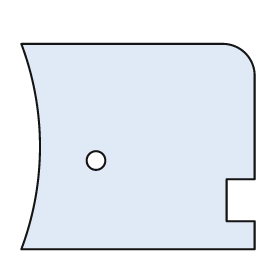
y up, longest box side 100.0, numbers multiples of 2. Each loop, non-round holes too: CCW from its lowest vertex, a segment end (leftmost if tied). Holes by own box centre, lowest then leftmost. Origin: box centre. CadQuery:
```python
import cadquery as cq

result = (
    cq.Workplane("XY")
    .moveTo(-50.0, -44.0)
    .lineTo(50.0, -44.0)
    .lineTo(50.0, -32.0)
    .lineTo(38.0, -32.0)
    .lineTo(38.0, -14.0)
    .lineTo(50.0, -14.0)
    .lineTo(50.0, 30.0)
    .threePointArc((46.0, 40.0), (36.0, 44.0))
    .lineTo(-50.0, 44.0)
    .threePointArc((-42.0, 0.0), (-50.0, -44.0))
    .close()
    .moveTo(-18.0, -6.0)
    .circle(4.0)
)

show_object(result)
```